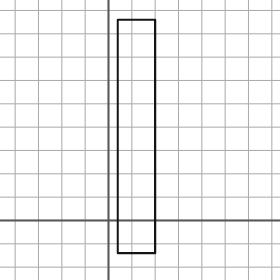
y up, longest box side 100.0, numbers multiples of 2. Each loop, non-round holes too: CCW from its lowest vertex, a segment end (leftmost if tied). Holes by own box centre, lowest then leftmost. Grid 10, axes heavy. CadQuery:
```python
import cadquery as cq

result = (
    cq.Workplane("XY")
    .moveTo(4.0, -14.0)
    .lineTo(20.0, -14.0)
    .lineTo(20.0, 86.0)
    .lineTo(4.0, 86.0)
    .close()
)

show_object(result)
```